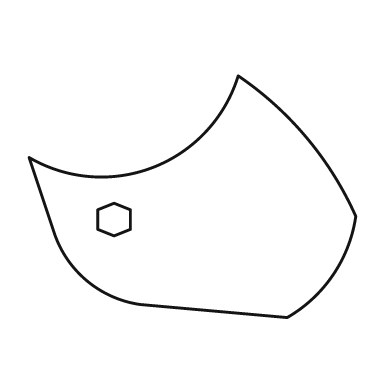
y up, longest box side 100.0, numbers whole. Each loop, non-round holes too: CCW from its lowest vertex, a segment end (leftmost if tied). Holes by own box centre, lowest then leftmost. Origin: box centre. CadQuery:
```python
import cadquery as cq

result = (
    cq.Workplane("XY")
    .moveTo(29.0, -37.0)
    .threePointArc((43.0, -24.0), (50.0, -6.0))
    .threePointArc((35.0, 18.0), (14.0, 37.0))
    .threePointArc((-12.0, 9.0), (-50.0, 12.0))
    .lineTo(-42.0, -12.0)
    .threePointArc((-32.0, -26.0), (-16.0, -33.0))
    .close()
    .moveTo(-24.0, -12.0)
    .lineTo(-19.0, -10.0)
    .lineTo(-19.0, -4.0)
    .lineTo(-24.0, -2.0)
    .lineTo(-29.0, -4.0)
    .lineTo(-29.0, -10.0)
    .close()
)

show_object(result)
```